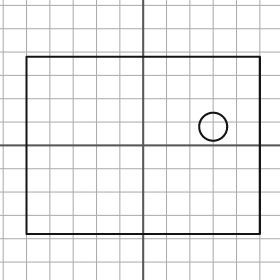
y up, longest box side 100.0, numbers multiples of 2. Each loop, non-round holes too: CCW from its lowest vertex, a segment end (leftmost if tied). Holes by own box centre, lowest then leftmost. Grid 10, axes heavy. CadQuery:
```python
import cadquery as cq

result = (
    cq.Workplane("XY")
    .moveTo(-50.0, -38.0)
    .lineTo(50.0, -38.0)
    .lineTo(50.0, 38.0)
    .lineTo(-50.0, 38.0)
    .close()
    .moveTo(30.0, 8.0)
    .circle(6.0)
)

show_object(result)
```